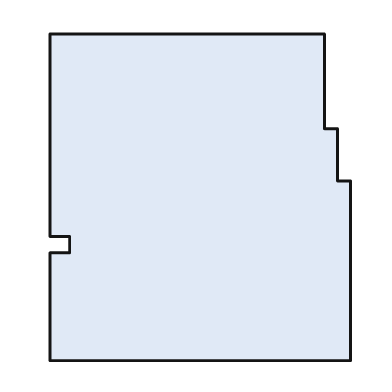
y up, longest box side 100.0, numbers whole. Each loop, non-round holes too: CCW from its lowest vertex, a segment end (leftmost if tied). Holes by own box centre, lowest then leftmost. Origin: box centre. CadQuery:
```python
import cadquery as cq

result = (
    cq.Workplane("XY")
    .moveTo(-46.0, -50.0)
    .lineTo(46.0, -50.0)
    .lineTo(46.0, 5.0)
    .lineTo(42.0, 5.0)
    .lineTo(42.0, 21.0)
    .lineTo(38.0, 21.0)
    .lineTo(38.0, 50.0)
    .lineTo(-46.0, 50.0)
    .lineTo(-46.0, -12.0)
    .lineTo(-40.0, -12.0)
    .lineTo(-40.0, -17.0)
    .lineTo(-46.0, -17.0)
    .close()
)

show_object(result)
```